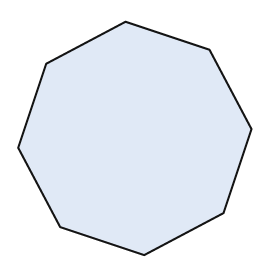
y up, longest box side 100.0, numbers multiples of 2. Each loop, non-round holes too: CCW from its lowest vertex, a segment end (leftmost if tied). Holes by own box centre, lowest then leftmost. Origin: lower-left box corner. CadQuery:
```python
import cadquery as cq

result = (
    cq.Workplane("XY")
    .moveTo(54.0, 0.0)
    .lineTo(88.0, 18.0)
    .lineTo(100.0, 54.0)
    .lineTo(82.0, 88.0)
    .lineTo(46.0, 100.0)
    .lineTo(12.0, 82.0)
    .lineTo(0.0, 46.0)
    .lineTo(18.0, 12.0)
    .close()
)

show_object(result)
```